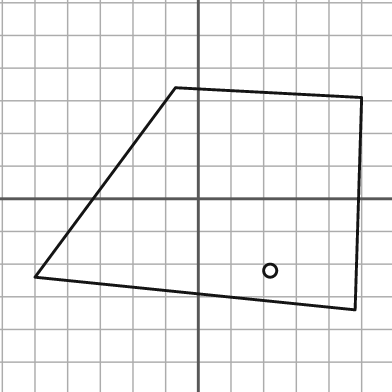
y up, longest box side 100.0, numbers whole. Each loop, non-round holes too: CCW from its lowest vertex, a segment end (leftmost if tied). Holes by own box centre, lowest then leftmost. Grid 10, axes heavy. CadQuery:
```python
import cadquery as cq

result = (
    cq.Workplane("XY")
    .moveTo(48.0, -34.0)
    .lineTo(50.0, 31.0)
    .lineTo(-7.0, 34.0)
    .lineTo(-50.0, -24.0)
    .close()
    .moveTo(22.0, -22.0)
    .circle(2.0)
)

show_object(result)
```